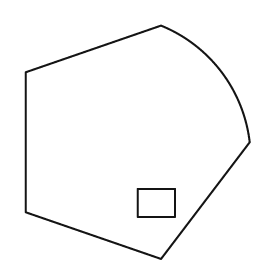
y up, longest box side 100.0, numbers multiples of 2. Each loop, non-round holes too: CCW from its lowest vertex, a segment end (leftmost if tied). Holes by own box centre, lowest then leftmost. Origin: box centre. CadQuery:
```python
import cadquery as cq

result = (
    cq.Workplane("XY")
    .moveTo(10.0, -50.0)
    .lineTo(48.0, 0.0)
    .threePointArc((36.0, 30.0), (10.0, 50.0))
    .lineTo(-48.0, 30.0)
    .lineTo(-48.0, -30.0)
    .close()
    .moveTo(0.0, -32.0)
    .lineTo(16.0, -32.0)
    .lineTo(16.0, -20.0)
    .lineTo(0.0, -20.0)
    .close()
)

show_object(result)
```